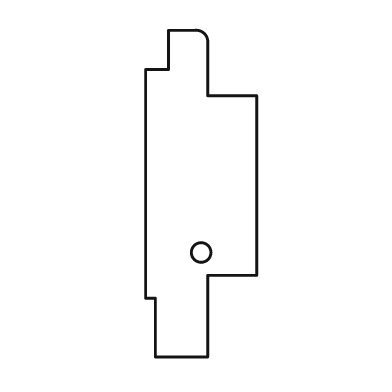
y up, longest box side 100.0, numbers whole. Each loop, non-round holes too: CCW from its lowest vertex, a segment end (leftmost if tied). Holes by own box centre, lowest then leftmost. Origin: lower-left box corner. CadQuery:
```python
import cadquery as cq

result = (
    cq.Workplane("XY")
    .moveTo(3.0, 0.0)
    .lineTo(19.0, 0.0)
    .lineTo(19.0, 25.0)
    .lineTo(34.0, 25.0)
    .lineTo(34.0, 80.0)
    .lineTo(19.0, 80.0)
    .lineTo(19.0, 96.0)
    .threePointArc((18.0, 99.0), (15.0, 100.0))
    .lineTo(7.0, 100.0)
    .lineTo(7.0, 88.0)
    .lineTo(0.0, 88.0)
    .lineTo(0.0, 18.0)
    .lineTo(3.0, 18.0)
    .close()
    .moveTo(17.0, 32.0)
    .circle(3.0)
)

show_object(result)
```